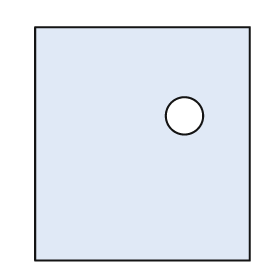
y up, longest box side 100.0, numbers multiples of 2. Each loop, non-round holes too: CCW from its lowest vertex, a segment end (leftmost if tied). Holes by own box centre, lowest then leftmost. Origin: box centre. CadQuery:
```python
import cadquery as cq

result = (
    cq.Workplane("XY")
    .moveTo(-46.0, -50.0)
    .lineTo(46.0, -50.0)
    .lineTo(46.0, 50.0)
    .lineTo(-46.0, 50.0)
    .close()
    .moveTo(18.0, 12.0)
    .circle(8.0)
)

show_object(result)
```